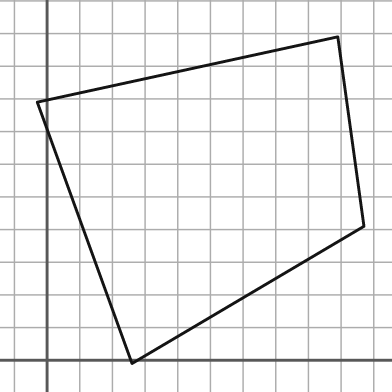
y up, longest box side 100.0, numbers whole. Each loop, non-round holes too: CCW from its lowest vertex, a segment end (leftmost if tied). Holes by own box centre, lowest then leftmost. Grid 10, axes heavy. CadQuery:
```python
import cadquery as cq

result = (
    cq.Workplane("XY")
    .moveTo(26.0, -1.0)
    .lineTo(97.0, 41.0)
    .lineTo(89.0, 99.0)
    .lineTo(-3.0, 79.0)
    .close()
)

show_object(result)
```